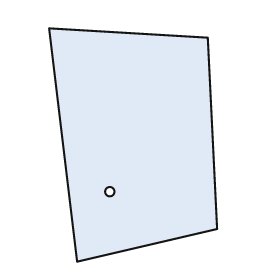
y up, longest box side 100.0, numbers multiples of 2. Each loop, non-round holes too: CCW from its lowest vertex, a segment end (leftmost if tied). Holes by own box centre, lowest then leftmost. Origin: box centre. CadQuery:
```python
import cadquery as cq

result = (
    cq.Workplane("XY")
    .moveTo(-24.0, -50.0)
    .lineTo(36.0, -36.0)
    .lineTo(32.0, 46.0)
    .lineTo(-36.0, 50.0)
    .close()
    .moveTo(-10.0, -20.0)
    .circle(2.0)
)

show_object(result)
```